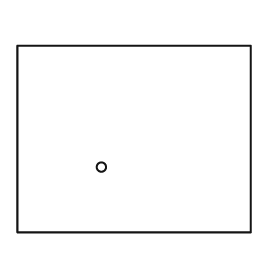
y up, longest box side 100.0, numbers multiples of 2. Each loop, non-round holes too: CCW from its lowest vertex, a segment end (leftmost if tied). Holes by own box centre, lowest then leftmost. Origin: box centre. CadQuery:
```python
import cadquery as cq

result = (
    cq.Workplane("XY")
    .moveTo(-50.0, -40.0)
    .lineTo(50.0, -40.0)
    .lineTo(50.0, 40.0)
    .lineTo(-50.0, 40.0)
    .close()
    .moveTo(-14.0, -12.0)
    .circle(2.0)
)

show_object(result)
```